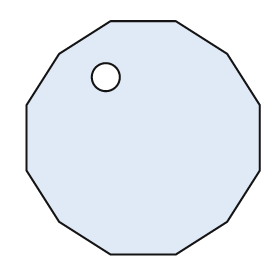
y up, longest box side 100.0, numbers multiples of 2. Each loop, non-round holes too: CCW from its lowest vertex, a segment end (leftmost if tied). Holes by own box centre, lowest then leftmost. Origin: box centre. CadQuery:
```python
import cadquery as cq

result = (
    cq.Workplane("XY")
    .moveTo(-14.0, -50.0)
    .lineTo(14.0, -50.0)
    .lineTo(36.0, -36.0)
    .lineTo(50.0, -14.0)
    .lineTo(50.0, 14.0)
    .lineTo(36.0, 36.0)
    .lineTo(14.0, 50.0)
    .lineTo(-14.0, 50.0)
    .lineTo(-36.0, 36.0)
    .lineTo(-50.0, 14.0)
    .lineTo(-50.0, -14.0)
    .lineTo(-36.0, -36.0)
    .close()
    .moveTo(-16.0, 26.0)
    .circle(6.0)
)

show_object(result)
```